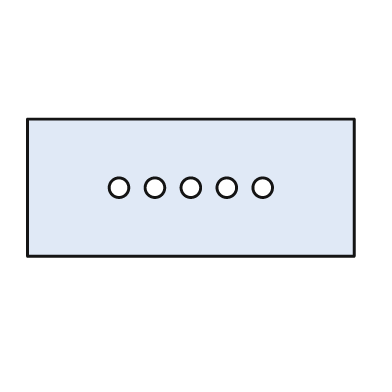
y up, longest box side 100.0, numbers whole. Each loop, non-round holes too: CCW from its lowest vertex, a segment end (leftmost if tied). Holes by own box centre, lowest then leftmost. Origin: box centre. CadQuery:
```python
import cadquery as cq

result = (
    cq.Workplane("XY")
    .moveTo(-50.0, -21.0)
    .lineTo(50.0, -21.0)
    .lineTo(50.0, 21.0)
    .lineTo(-50.0, 21.0)
    .close()
    .moveTo(-22.0, 0.0)
    .circle(3.0)
    .moveTo(-11.0, 0.0)
    .circle(3.0)
    .moveTo(0.0, 0.0)
    .circle(3.0)
    .moveTo(11.0, 0.0)
    .circle(3.0)
    .moveTo(22.0, 0.0)
    .circle(3.0)
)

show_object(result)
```